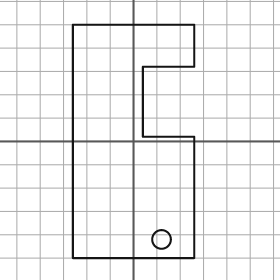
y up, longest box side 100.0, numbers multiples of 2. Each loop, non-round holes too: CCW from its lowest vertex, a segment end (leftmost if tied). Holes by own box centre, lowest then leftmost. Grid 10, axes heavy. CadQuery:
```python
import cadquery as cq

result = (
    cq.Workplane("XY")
    .moveTo(-26.0, -50.0)
    .lineTo(26.0, -50.0)
    .lineTo(26.0, 2.0)
    .lineTo(4.0, 2.0)
    .lineTo(4.0, 32.0)
    .lineTo(26.0, 32.0)
    .lineTo(26.0, 50.0)
    .lineTo(-26.0, 50.0)
    .close()
    .moveTo(12.0, -42.0)
    .circle(4.0)
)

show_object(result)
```